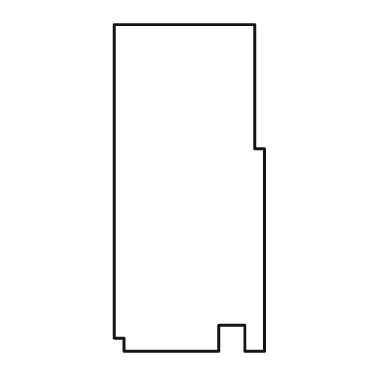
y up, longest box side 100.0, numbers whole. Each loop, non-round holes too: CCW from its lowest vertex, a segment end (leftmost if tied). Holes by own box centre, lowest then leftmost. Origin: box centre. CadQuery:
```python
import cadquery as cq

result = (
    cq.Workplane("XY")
    .moveTo(-20.0, -50.0)
    .lineTo(9.0, -50.0)
    .lineTo(9.0, -42.0)
    .lineTo(17.0, -42.0)
    .lineTo(17.0, -50.0)
    .lineTo(23.0, -50.0)
    .lineTo(23.0, 12.0)
    .lineTo(20.0, 12.0)
    .lineTo(20.0, 50.0)
    .lineTo(-23.0, 50.0)
    .lineTo(-23.0, -46.0)
    .lineTo(-20.0, -46.0)
    .close()
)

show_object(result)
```